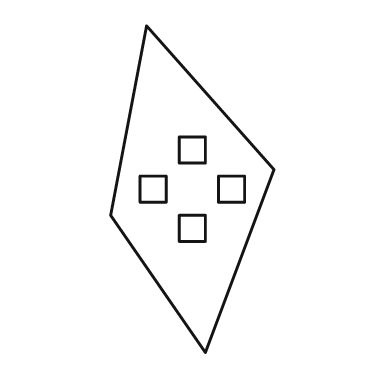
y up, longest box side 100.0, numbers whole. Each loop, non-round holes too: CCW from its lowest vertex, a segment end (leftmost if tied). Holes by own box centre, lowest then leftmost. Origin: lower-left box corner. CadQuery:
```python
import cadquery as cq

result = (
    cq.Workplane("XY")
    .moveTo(29.0, 0.0)
    .lineTo(50.0, 56.0)
    .lineTo(11.0, 100.0)
    .lineTo(0.0, 42.0)
    .close()
    .moveTo(21.0, 34.0)
    .lineTo(29.0, 34.0)
    .lineTo(29.0, 42.0)
    .lineTo(21.0, 42.0)
    .close()
    .moveTo(9.0, 46.0)
    .lineTo(17.0, 46.0)
    .lineTo(17.0, 54.0)
    .lineTo(9.0, 54.0)
    .close()
    .moveTo(33.0, 46.0)
    .lineTo(41.0, 46.0)
    .lineTo(41.0, 54.0)
    .lineTo(33.0, 54.0)
    .close()
    .moveTo(21.0, 58.0)
    .lineTo(29.0, 58.0)
    .lineTo(29.0, 66.0)
    .lineTo(21.0, 66.0)
    .close()
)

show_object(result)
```